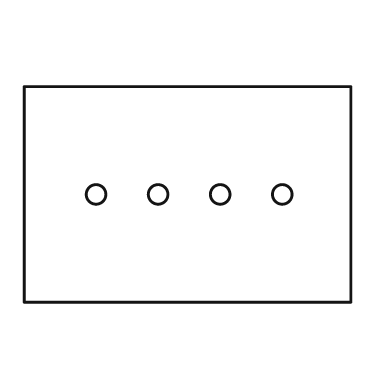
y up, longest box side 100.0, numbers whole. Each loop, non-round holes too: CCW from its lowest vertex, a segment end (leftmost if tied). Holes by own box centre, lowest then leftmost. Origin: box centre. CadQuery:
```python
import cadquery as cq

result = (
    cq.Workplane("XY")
    .moveTo(-50.0, -33.0)
    .lineTo(50.0, -33.0)
    .lineTo(50.0, 33.0)
    .lineTo(-50.0, 33.0)
    .close()
    .moveTo(-28.0, 0.0)
    .circle(3.0)
    .moveTo(-9.0, 0.0)
    .circle(3.0)
    .moveTo(10.0, 0.0)
    .circle(3.0)
    .moveTo(29.0, 0.0)
    .circle(3.0)
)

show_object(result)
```